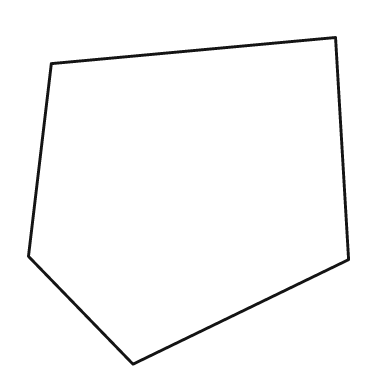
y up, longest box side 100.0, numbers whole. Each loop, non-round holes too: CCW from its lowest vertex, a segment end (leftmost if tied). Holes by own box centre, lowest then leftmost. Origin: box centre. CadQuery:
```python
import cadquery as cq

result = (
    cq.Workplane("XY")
    .moveTo(-17.0, -50.0)
    .lineTo(49.0, -18.0)
    .lineTo(45.0, 50.0)
    .lineTo(-42.0, 42.0)
    .lineTo(-49.0, -17.0)
    .close()
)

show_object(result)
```